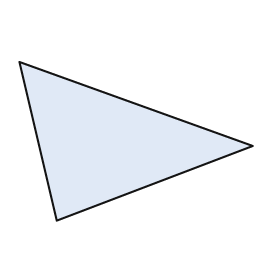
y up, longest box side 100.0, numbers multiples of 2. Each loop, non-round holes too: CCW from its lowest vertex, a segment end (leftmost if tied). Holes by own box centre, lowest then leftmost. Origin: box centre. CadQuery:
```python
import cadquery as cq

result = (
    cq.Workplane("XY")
    .moveTo(-34.0, -34.0)
    .lineTo(50.0, -2.0)
    .lineTo(-50.0, 34.0)
    .close()
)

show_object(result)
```